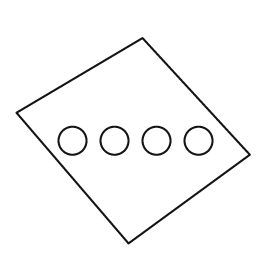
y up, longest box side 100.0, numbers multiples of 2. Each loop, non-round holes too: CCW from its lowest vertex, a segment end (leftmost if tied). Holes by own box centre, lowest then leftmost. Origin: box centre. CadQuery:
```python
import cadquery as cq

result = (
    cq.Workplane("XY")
    .moveTo(-2.0, -44.0)
    .lineTo(50.0, -6.0)
    .lineTo(4.0, 44.0)
    .lineTo(-50.0, 12.0)
    .close()
    .moveTo(-26.0, 0.0)
    .circle(6.0)
    .moveTo(-8.0, 0.0)
    .circle(6.0)
    .moveTo(10.0, 0.0)
    .circle(6.0)
    .moveTo(28.0, 0.0)
    .circle(6.0)
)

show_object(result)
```